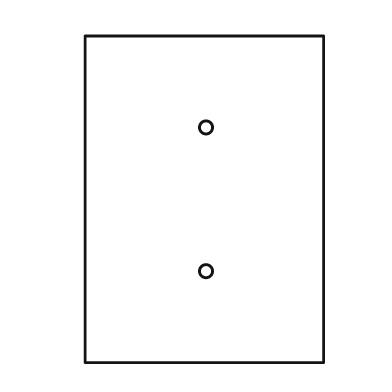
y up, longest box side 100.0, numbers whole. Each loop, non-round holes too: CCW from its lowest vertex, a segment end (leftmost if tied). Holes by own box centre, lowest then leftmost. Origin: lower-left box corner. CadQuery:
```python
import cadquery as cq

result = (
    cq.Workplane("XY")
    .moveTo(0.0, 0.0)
    .lineTo(73.0, 0.0)
    .lineTo(73.0, 100.0)
    .lineTo(0.0, 100.0)
    .close()
    .moveTo(37.0, 28.0)
    .circle(2.0)
    .moveTo(37.0, 72.0)
    .circle(2.0)
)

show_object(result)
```